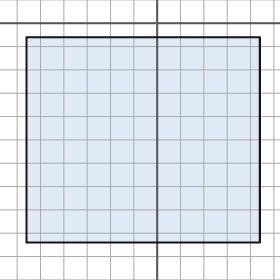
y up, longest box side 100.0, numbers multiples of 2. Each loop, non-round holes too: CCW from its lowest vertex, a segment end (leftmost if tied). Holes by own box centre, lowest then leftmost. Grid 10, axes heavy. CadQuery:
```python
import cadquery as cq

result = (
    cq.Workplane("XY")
    .moveTo(-56.0, -94.0)
    .lineTo(44.0, -94.0)
    .lineTo(44.0, -6.0)
    .lineTo(-56.0, -6.0)
    .close()
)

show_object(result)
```